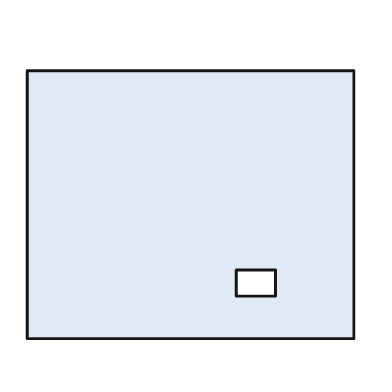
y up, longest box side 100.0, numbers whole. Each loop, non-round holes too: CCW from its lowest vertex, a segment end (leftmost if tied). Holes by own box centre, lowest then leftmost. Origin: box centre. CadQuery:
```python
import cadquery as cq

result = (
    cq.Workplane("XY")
    .moveTo(-50.0, -41.0)
    .lineTo(50.0, -41.0)
    .lineTo(50.0, 41.0)
    .lineTo(-50.0, 41.0)
    .close()
    .moveTo(14.0, -28.0)
    .lineTo(26.0, -28.0)
    .lineTo(26.0, -20.0)
    .lineTo(14.0, -20.0)
    .close()
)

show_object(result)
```